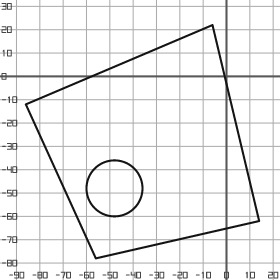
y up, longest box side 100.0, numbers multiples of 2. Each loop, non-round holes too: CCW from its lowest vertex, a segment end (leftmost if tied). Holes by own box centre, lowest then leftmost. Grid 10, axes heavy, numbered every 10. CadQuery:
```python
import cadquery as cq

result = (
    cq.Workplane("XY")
    .moveTo(-56.0, -78.0)
    .lineTo(14.0, -62.0)
    .lineTo(-6.0, 22.0)
    .lineTo(-86.0, -12.0)
    .close()
    .moveTo(-48.0, -48.0)
    .circle(12.0)
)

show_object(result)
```